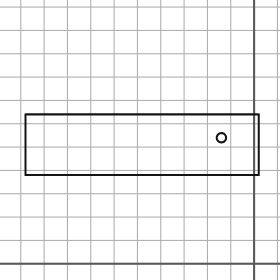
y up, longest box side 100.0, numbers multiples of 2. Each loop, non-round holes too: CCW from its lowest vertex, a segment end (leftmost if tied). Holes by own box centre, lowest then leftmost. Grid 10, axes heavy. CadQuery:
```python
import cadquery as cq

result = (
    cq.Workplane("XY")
    .moveTo(-98.0, 38.0)
    .lineTo(2.0, 38.0)
    .lineTo(2.0, 64.0)
    .lineTo(-98.0, 64.0)
    .close()
    .moveTo(-14.0, 54.0)
    .circle(2.0)
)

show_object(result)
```